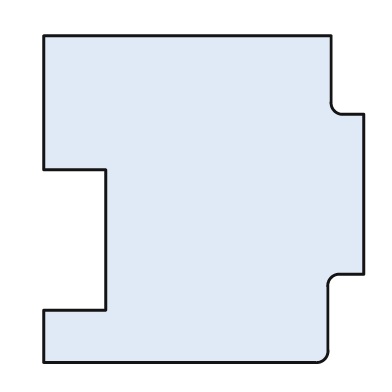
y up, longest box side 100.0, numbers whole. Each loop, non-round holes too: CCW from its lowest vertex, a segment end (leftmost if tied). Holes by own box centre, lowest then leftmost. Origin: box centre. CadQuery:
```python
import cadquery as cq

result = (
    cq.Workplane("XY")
    .moveTo(-49.0, -50.0)
    .lineTo(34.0, -50.0)
    .threePointArc((37.0, -49.0), (38.0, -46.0))
    .lineTo(38.0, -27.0)
    .threePointArc((39.0, -24.0), (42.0, -23.0))
    .lineTo(49.0, -23.0)
    .lineTo(49.0, 26.0)
    .lineTo(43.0, 26.0)
    .threePointArc((40.0, 27.0), (39.0, 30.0))
    .lineTo(39.0, 50.0)
    .lineTo(-49.0, 50.0)
    .lineTo(-49.0, 9.0)
    .lineTo(-30.0, 9.0)
    .lineTo(-30.0, -34.0)
    .lineTo(-49.0, -34.0)
    .close()
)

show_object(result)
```